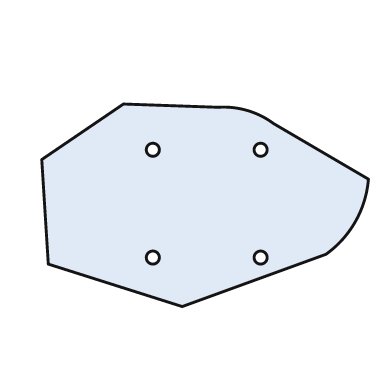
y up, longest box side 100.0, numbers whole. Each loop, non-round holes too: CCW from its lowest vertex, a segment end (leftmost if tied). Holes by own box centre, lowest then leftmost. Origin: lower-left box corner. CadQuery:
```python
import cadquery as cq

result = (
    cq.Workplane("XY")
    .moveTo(43.0, 0.0)
    .lineTo(87.0, 16.0)
    .threePointArc((96.0, 26.0), (100.0, 39.0))
    .lineTo(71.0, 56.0)
    .threePointArc((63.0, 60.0), (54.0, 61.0))
    .lineTo(25.0, 62.0)
    .lineTo(0.0, 45.0)
    .lineTo(2.0, 13.0)
    .close()
    .moveTo(34.0, 15.0)
    .circle(2.0)
    .moveTo(67.0, 15.0)
    .circle(2.0)
    .moveTo(34.0, 48.0)
    .circle(2.0)
    .moveTo(67.0, 48.0)
    .circle(2.0)
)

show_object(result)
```